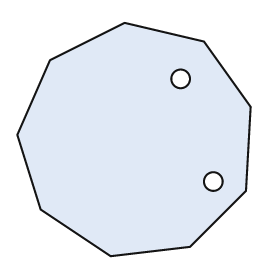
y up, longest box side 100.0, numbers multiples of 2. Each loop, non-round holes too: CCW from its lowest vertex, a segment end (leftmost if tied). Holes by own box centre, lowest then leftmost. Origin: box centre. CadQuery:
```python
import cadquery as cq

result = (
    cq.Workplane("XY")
    .moveTo(-10.0, -50.0)
    .lineTo(24.0, -46.0)
    .lineTo(48.0, -22.0)
    .lineTo(50.0, 14.0)
    .lineTo(30.0, 42.0)
    .lineTo(-4.0, 50.0)
    .lineTo(-36.0, 34.0)
    .lineTo(-50.0, 2.0)
    .lineTo(-40.0, -30.0)
    .close()
    .moveTo(34.0, -18.0)
    .circle(4.0)
    .moveTo(20.0, 26.0)
    .circle(4.0)
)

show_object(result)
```